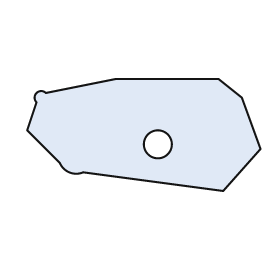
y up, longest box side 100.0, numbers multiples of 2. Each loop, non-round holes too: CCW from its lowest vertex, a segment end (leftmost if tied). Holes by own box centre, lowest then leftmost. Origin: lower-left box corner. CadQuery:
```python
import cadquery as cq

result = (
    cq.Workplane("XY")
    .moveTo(84.0, 0.0)
    .lineTo(100.0, 18.0)
    .lineTo(92.0, 40.0)
    .lineTo(82.0, 48.0)
    .lineTo(38.0, 48.0)
    .lineTo(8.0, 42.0)
    .threePointArc((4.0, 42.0), (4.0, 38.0))
    .lineTo(0.0, 26.0)
    .lineTo(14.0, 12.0)
    .threePointArc((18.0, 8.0), (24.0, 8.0))
    .close()
    .moveTo(56.0, 20.0)
    .circle(6.0)
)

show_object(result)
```